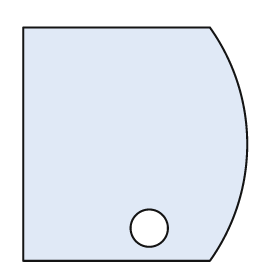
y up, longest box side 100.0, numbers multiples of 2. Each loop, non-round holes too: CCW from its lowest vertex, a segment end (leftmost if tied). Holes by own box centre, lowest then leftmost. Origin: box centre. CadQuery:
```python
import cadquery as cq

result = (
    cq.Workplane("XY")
    .moveTo(-48.0, -50.0)
    .lineTo(32.0, -50.0)
    .threePointArc((48.0, 0.0), (32.0, 50.0))
    .lineTo(-48.0, 50.0)
    .close()
    .moveTo(6.0, -36.0)
    .circle(8.0)
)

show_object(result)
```